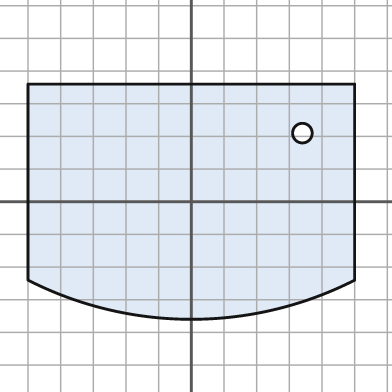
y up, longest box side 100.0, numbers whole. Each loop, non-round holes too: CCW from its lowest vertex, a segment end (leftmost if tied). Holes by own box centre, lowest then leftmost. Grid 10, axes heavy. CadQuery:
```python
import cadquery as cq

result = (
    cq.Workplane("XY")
    .moveTo(-50.0, -24.0)
    .threePointArc((0.0, -36.0), (50.0, -24.0))
    .lineTo(50.0, 36.0)
    .lineTo(-50.0, 36.0)
    .close()
    .moveTo(34.0, 21.0)
    .circle(3.0)
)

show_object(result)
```